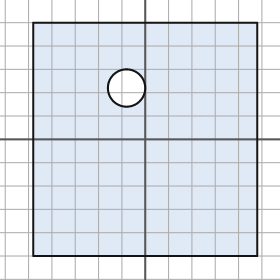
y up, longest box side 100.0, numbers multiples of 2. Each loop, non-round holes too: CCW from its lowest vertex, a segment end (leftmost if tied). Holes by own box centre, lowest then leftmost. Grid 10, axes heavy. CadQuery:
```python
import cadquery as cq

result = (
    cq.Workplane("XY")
    .moveTo(-48.0, -50.0)
    .lineTo(48.0, -50.0)
    .lineTo(48.0, 50.0)
    .lineTo(-48.0, 50.0)
    .close()
    .moveTo(-8.0, 22.0)
    .circle(8.0)
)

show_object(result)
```